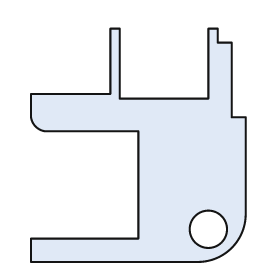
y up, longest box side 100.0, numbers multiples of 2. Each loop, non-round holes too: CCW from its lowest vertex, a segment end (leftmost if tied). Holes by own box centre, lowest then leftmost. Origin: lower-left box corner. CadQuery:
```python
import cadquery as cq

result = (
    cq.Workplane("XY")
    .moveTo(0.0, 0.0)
    .lineTo(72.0, 0.0)
    .threePointArc((86.0, 6.0), (92.0, 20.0))
    .lineTo(92.0, 62.0)
    .lineTo(86.0, 62.0)
    .lineTo(86.0, 94.0)
    .lineTo(80.0, 94.0)
    .lineTo(80.0, 100.0)
    .lineTo(76.0, 100.0)
    .lineTo(76.0, 70.0)
    .lineTo(38.0, 70.0)
    .lineTo(38.0, 100.0)
    .lineTo(34.0, 100.0)
    .lineTo(34.0, 72.0)
    .lineTo(0.0, 72.0)
    .lineTo(0.0, 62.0)
    .threePointArc((2.0, 58.0), (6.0, 56.0))
    .lineTo(46.0, 56.0)
    .lineTo(46.0, 10.0)
    .lineTo(0.0, 10.0)
    .close()
    .moveTo(76.0, 14.0)
    .circle(8.0)
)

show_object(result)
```